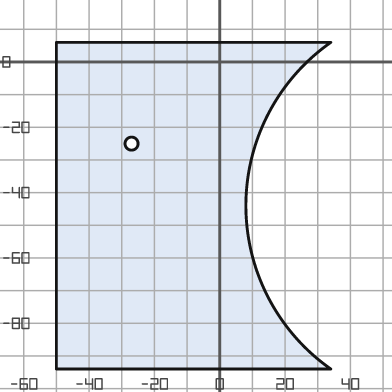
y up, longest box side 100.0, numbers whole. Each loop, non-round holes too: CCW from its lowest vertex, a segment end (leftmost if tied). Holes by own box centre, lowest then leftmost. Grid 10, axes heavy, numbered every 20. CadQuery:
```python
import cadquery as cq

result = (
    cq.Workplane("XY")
    .moveTo(-50.0, -94.0)
    .lineTo(34.0, -94.0)
    .threePointArc((8.0, -44.0), (34.0, 6.0))
    .lineTo(-50.0, 6.0)
    .close()
    .moveTo(-27.0, -25.0)
    .circle(2.0)
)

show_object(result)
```